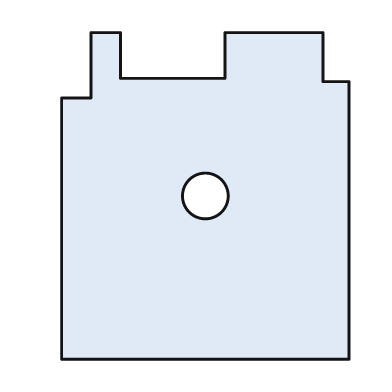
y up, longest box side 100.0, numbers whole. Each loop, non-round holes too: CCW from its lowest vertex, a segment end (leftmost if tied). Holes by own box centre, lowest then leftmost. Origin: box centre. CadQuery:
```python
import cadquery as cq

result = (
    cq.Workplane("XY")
    .moveTo(-44.0, -50.0)
    .lineTo(44.0, -50.0)
    .lineTo(44.0, 35.0)
    .lineTo(36.0, 35.0)
    .lineTo(36.0, 50.0)
    .lineTo(6.0, 50.0)
    .lineTo(6.0, 36.0)
    .lineTo(-26.0, 36.0)
    .lineTo(-26.0, 50.0)
    .lineTo(-35.0, 50.0)
    .lineTo(-35.0, 30.0)
    .lineTo(-44.0, 30.0)
    .close()
    .moveTo(0.0, 0.0)
    .circle(7.0)
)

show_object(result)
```